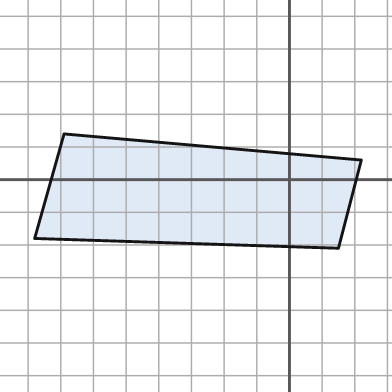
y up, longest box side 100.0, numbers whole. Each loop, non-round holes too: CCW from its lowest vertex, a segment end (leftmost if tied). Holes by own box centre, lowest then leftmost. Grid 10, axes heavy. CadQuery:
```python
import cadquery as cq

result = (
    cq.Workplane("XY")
    .moveTo(15.0, -21.0)
    .lineTo(22.0, 6.0)
    .lineTo(-69.0, 14.0)
    .lineTo(-78.0, -18.0)
    .close()
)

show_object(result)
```